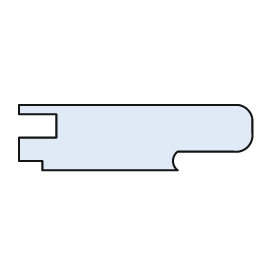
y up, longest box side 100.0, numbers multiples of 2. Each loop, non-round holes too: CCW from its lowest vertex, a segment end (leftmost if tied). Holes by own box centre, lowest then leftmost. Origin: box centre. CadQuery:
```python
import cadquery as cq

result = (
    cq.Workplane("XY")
    .moveTo(-40.0, -14.0)
    .lineTo(18.0, -14.0)
    .threePointArc((16.0, -10.0), (18.0, -6.0))
    .lineTo(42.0, -6.0)
    .threePointArc((48.0, -4.0), (50.0, 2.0))
    .lineTo(50.0, 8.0)
    .threePointArc((48.0, 12.0), (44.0, 14.0))
    .lineTo(-50.0, 14.0)
    .lineTo(-50.0, 10.0)
    .lineTo(-34.0, 10.0)
    .lineTo(-34.0, 0.0)
    .lineTo(-50.0, 0.0)
    .lineTo(-50.0, -10.0)
    .lineTo(-40.0, -10.0)
    .close()
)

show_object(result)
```